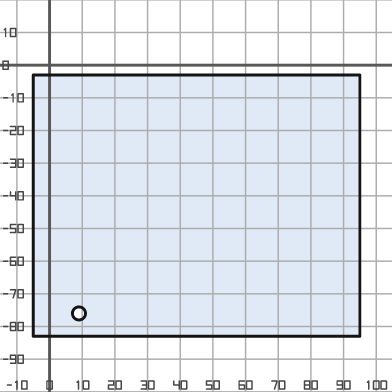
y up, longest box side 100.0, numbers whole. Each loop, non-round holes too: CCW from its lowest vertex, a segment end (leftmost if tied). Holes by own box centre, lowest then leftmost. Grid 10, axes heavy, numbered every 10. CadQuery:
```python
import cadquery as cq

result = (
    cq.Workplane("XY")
    .moveTo(-5.0, -83.0)
    .lineTo(95.0, -83.0)
    .lineTo(95.0, -3.0)
    .lineTo(-5.0, -3.0)
    .close()
    .moveTo(9.0, -76.0)
    .circle(2.0)
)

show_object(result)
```